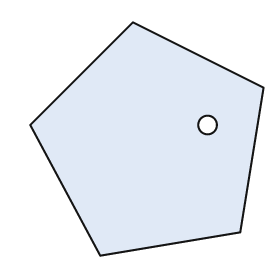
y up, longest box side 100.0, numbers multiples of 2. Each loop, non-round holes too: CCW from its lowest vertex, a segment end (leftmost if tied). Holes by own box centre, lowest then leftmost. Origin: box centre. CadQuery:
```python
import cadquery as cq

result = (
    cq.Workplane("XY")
    .moveTo(-20.0, -50.0)
    .lineTo(40.0, -40.0)
    .lineTo(50.0, 22.0)
    .lineTo(-6.0, 50.0)
    .lineTo(-50.0, 6.0)
    .close()
    .moveTo(26.0, 6.0)
    .circle(4.0)
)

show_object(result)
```